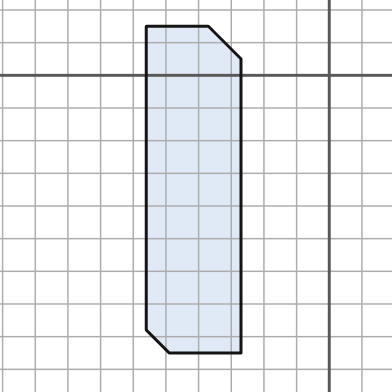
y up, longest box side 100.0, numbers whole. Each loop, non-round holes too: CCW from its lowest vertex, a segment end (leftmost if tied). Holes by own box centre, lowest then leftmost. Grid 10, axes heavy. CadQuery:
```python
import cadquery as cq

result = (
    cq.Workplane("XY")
    .moveTo(-49.0, -85.0)
    .lineTo(-27.0, -85.0)
    .lineTo(-27.0, 5.0)
    .lineTo(-37.0, 15.0)
    .lineTo(-56.0, 15.0)
    .lineTo(-56.0, -78.0)
    .close()
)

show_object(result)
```